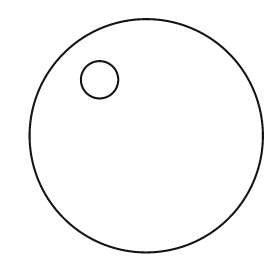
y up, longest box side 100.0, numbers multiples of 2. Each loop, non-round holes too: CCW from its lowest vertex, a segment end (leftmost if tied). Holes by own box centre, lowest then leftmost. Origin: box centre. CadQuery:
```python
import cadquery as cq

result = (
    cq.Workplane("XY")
    .moveTo(0.0, 0.0)
    .circle(50.0)
    .moveTo(-20.0, 24.0)
    .circle(8.0)
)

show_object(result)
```